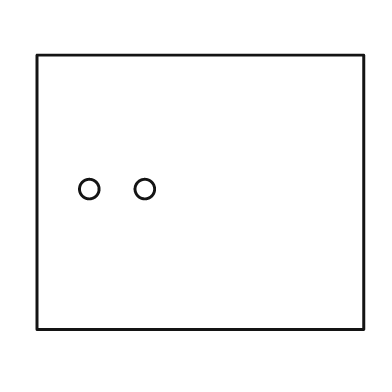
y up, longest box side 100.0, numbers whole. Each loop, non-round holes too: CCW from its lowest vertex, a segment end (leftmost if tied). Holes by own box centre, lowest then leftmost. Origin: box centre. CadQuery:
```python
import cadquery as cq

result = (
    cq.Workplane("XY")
    .moveTo(-50.0, -42.0)
    .lineTo(50.0, -42.0)
    .lineTo(50.0, 42.0)
    .lineTo(-50.0, 42.0)
    .close()
    .moveTo(-34.0, 1.0)
    .circle(3.0)
    .moveTo(-17.0, 1.0)
    .circle(3.0)
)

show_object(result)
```